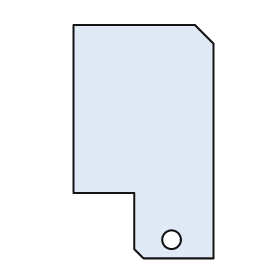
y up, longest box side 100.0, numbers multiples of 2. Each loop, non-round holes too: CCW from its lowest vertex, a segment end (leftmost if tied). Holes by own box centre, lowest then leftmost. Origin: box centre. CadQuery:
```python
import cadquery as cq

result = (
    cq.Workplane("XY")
    .moveTo(0.0, -50.0)
    .lineTo(30.0, -50.0)
    .lineTo(30.0, 42.0)
    .lineTo(22.0, 50.0)
    .lineTo(-30.0, 50.0)
    .lineTo(-30.0, -22.0)
    .lineTo(-4.0, -22.0)
    .lineTo(-4.0, -46.0)
    .close()
    .moveTo(12.0, -42.0)
    .circle(4.0)
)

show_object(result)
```